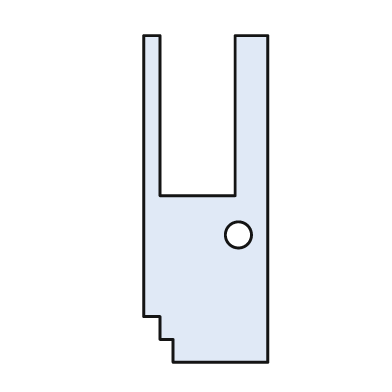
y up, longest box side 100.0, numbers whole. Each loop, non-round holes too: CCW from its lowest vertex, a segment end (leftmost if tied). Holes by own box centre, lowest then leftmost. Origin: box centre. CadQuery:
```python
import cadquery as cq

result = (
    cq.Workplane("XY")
    .moveTo(-10.0, -50.0)
    .lineTo(19.0, -50.0)
    .lineTo(19.0, 50.0)
    .lineTo(9.0, 50.0)
    .lineTo(9.0, 1.0)
    .lineTo(-14.0, 1.0)
    .lineTo(-14.0, 50.0)
    .lineTo(-19.0, 50.0)
    .lineTo(-19.0, -36.0)
    .lineTo(-14.0, -36.0)
    .lineTo(-14.0, -43.0)
    .lineTo(-10.0, -43.0)
    .close()
    .moveTo(10.0, -11.0)
    .circle(4.0)
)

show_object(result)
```